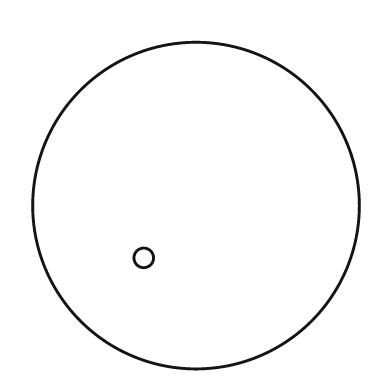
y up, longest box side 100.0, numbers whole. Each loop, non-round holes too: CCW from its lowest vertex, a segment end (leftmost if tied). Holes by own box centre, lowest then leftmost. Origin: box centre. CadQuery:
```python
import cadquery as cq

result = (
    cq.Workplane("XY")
    .moveTo(0.0, 0.0)
    .circle(50.0)
    .moveTo(-16.0, -16.0)
    .circle(3.0)
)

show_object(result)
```